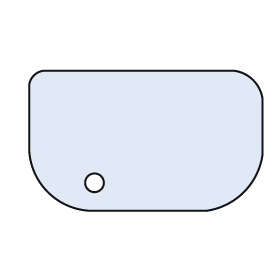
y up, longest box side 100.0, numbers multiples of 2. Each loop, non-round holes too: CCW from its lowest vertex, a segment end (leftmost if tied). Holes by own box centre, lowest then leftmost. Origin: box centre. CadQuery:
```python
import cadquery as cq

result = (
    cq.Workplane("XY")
    .moveTo(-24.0, -30.0)
    .lineTo(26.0, -30.0)
    .threePointArc((42.0, -22.0), (50.0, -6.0))
    .lineTo(50.0, 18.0)
    .threePointArc((46.0, 26.0), (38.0, 30.0))
    .lineTo(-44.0, 30.0)
    .threePointArc((-48.0, 28.0), (-50.0, 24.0))
    .lineTo(-50.0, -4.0)
    .threePointArc((-42.0, -22.0), (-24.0, -30.0))
    .close()
    .moveTo(-22.0, -18.0)
    .circle(4.0)
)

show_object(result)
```